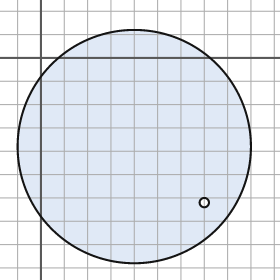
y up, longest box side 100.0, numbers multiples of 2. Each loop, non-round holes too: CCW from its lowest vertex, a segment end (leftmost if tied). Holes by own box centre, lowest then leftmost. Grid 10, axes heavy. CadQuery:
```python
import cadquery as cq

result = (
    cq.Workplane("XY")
    .moveTo(40.0, -38.0)
    .circle(50.0)
    .moveTo(70.0, -62.0)
    .circle(2.0)
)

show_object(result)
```